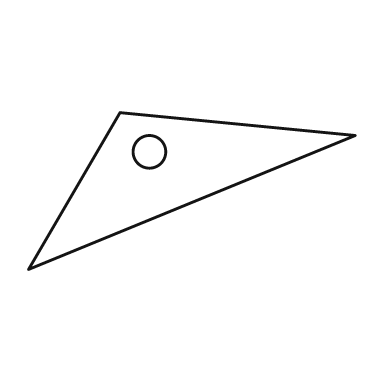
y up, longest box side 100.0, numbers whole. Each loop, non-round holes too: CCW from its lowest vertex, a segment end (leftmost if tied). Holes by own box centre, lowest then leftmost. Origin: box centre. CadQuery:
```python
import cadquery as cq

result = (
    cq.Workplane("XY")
    .moveTo(-50.0, -24.0)
    .lineTo(50.0, 17.0)
    .lineTo(-22.0, 24.0)
    .close()
    .moveTo(-13.0, 12.0)
    .circle(5.0)
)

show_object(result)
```